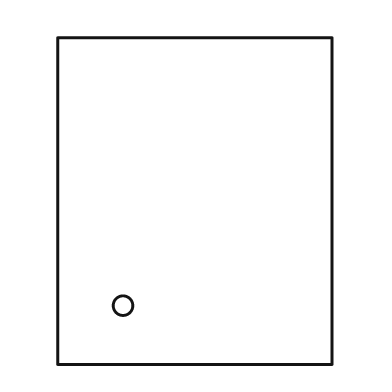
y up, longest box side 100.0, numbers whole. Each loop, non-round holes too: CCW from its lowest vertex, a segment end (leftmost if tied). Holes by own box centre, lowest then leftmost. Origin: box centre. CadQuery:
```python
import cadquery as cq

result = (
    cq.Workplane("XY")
    .moveTo(-42.0, -50.0)
    .lineTo(42.0, -50.0)
    .lineTo(42.0, 50.0)
    .lineTo(-42.0, 50.0)
    .close()
    .moveTo(-22.0, -32.0)
    .circle(3.0)
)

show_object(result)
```